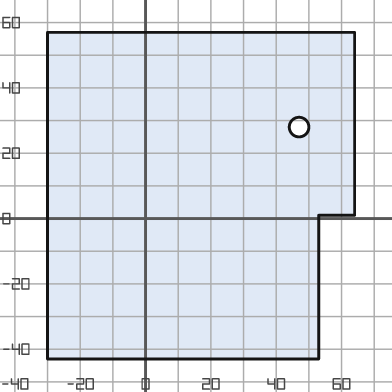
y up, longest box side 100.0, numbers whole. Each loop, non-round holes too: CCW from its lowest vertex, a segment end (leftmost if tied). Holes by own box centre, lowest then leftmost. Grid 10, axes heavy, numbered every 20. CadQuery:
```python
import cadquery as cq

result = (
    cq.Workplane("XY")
    .moveTo(-30.0, -43.0)
    .lineTo(53.0, -43.0)
    .lineTo(53.0, 1.0)
    .lineTo(64.0, 1.0)
    .lineTo(64.0, 57.0)
    .lineTo(-30.0, 57.0)
    .close()
    .moveTo(47.0, 28.0)
    .circle(3.0)
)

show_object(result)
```